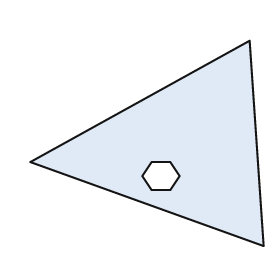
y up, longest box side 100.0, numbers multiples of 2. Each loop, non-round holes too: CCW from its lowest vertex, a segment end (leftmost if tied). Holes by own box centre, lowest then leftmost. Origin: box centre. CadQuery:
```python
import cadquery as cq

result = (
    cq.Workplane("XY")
    .moveTo(50.0, -44.0)
    .lineTo(44.0, 44.0)
    .lineTo(-50.0, -8.0)
    .close()
    .moveTo(2.0, -20.0)
    .lineTo(10.0, -20.0)
    .lineTo(14.0, -14.0)
    .lineTo(10.0, -8.0)
    .lineTo(2.0, -8.0)
    .lineTo(-2.0, -14.0)
    .close()
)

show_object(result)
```